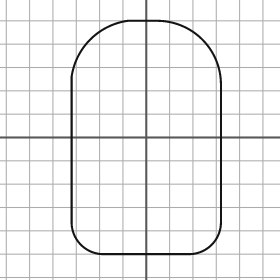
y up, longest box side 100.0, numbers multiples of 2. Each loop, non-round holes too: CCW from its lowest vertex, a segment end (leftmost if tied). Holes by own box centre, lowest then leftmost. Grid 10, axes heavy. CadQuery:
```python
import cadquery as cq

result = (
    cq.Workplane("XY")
    .moveTo(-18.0, -50.0)
    .lineTo(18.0, -50.0)
    .threePointArc((28.0, -46.0), (32.0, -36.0))
    .lineTo(32.0, 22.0)
    .threePointArc((24.0, 42.0), (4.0, 50.0))
    .lineTo(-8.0, 50.0)
    .threePointArc((-24.0, 42.0), (-32.0, 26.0))
    .lineTo(-32.0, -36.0)
    .threePointArc((-28.0, -46.0), (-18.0, -50.0))
    .close()
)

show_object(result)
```